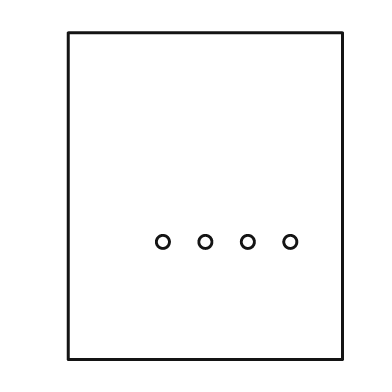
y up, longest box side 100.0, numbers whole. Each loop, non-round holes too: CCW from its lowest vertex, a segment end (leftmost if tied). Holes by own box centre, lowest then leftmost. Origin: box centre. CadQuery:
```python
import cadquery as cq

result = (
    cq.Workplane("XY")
    .moveTo(-42.0, -50.0)
    .lineTo(42.0, -50.0)
    .lineTo(42.0, 50.0)
    .lineTo(-42.0, 50.0)
    .close()
    .moveTo(-13.0, -14.0)
    .circle(2.0)
    .moveTo(0.0, -14.0)
    .circle(2.0)
    .moveTo(13.0, -14.0)
    .circle(2.0)
    .moveTo(26.0, -14.0)
    .circle(2.0)
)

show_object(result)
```